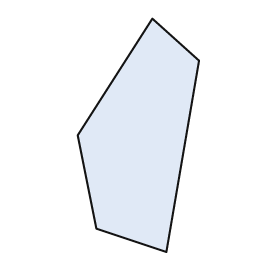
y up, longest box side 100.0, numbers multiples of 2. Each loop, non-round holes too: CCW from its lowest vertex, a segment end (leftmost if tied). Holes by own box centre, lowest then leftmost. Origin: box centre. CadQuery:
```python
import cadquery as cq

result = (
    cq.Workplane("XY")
    .moveTo(12.0, -50.0)
    .lineTo(26.0, 32.0)
    .lineTo(6.0, 50.0)
    .lineTo(-26.0, 0.0)
    .lineTo(-18.0, -40.0)
    .close()
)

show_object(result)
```